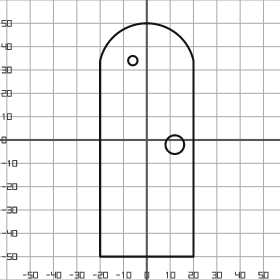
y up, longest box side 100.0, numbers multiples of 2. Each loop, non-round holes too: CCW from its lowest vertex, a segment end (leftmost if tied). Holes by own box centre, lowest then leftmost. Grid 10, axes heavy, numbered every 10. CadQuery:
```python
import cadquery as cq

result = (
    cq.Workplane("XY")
    .moveTo(-20.0, -50.0)
    .lineTo(20.0, -50.0)
    .lineTo(20.0, 34.0)
    .threePointArc((0.0, 50.0), (-20.0, 34.0))
    .close()
    .moveTo(12.0, -2.0)
    .circle(4.0)
    .moveTo(-6.0, 34.0)
    .circle(2.0)
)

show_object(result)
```